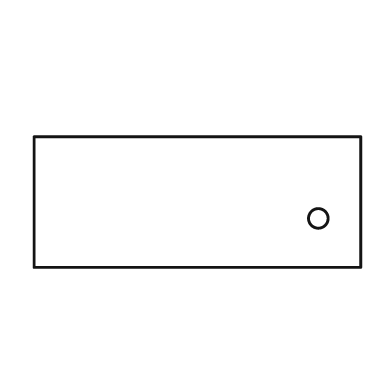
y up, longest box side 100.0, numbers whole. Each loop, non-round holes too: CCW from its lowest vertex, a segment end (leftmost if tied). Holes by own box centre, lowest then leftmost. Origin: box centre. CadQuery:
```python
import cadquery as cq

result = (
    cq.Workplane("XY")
    .moveTo(-50.0, -20.0)
    .lineTo(50.0, -20.0)
    .lineTo(50.0, 20.0)
    .lineTo(-50.0, 20.0)
    .close()
    .moveTo(37.0, -5.0)
    .circle(3.0)
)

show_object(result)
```